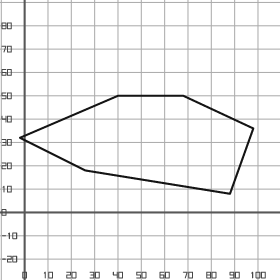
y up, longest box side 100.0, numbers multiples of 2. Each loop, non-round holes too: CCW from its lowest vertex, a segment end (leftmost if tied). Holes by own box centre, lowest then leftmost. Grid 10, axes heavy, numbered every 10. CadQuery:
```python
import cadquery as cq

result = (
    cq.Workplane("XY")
    .moveTo(88.0, 8.0)
    .lineTo(98.0, 36.0)
    .lineTo(68.0, 50.0)
    .lineTo(40.0, 50.0)
    .lineTo(-2.0, 32.0)
    .lineTo(26.0, 18.0)
    .close()
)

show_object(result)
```